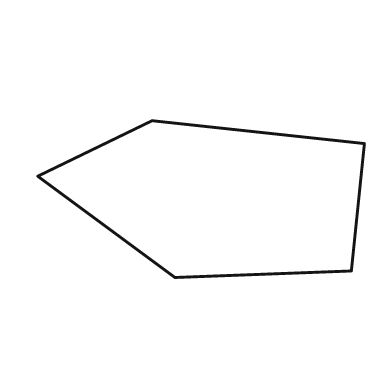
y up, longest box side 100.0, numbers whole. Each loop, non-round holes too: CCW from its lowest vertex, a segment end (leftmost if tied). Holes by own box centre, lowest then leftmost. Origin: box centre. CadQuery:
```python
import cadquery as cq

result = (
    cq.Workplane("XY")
    .moveTo(-8.0, -24.0)
    .lineTo(46.0, -22.0)
    .lineTo(50.0, 17.0)
    .lineTo(-15.0, 24.0)
    .lineTo(-50.0, 7.0)
    .close()
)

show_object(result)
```